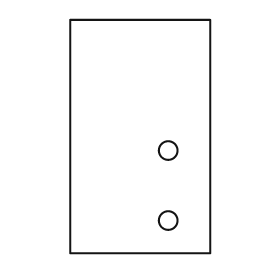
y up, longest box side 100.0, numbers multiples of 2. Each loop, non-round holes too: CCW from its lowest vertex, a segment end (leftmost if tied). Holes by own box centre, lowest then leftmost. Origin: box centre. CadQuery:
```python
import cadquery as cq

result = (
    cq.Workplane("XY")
    .moveTo(-30.0, -50.0)
    .lineTo(30.0, -50.0)
    .lineTo(30.0, 50.0)
    .lineTo(-30.0, 50.0)
    .close()
    .moveTo(12.0, -36.0)
    .circle(4.0)
    .moveTo(12.0, -6.0)
    .circle(4.0)
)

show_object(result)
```